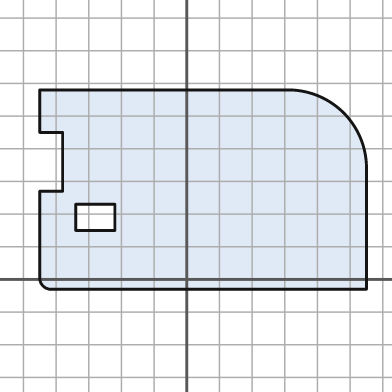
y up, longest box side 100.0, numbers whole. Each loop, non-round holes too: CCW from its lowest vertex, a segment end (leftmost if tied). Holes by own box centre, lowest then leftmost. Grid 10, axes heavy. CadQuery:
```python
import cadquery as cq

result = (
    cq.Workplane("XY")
    .moveTo(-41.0, -3.0)
    .lineTo(55.0, -3.0)
    .lineTo(55.0, 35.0)
    .threePointArc((48.0, 51.0), (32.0, 58.0))
    .lineTo(-45.0, 58.0)
    .lineTo(-45.0, 45.0)
    .lineTo(-38.0, 45.0)
    .lineTo(-38.0, 27.0)
    .lineTo(-45.0, 27.0)
    .lineTo(-45.0, 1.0)
    .threePointArc((-44.0, -2.0), (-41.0, -3.0))
    .close()
    .moveTo(-34.0, 15.0)
    .lineTo(-22.0, 15.0)
    .lineTo(-22.0, 23.0)
    .lineTo(-34.0, 23.0)
    .close()
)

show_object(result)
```